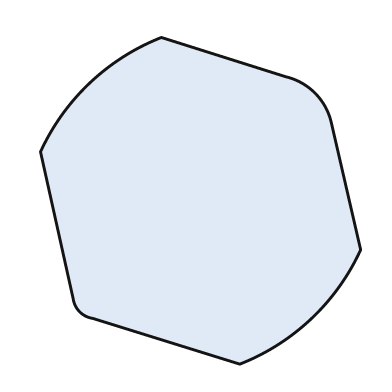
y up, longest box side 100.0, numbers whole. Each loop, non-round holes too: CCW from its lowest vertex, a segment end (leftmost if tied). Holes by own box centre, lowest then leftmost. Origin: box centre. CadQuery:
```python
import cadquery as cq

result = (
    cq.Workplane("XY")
    .moveTo(12.0, -50.0)
    .threePointArc((34.0, -36.0), (49.0, -15.0))
    .lineTo(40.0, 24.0)
    .threePointArc((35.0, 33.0), (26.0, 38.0))
    .lineTo(-12.0, 50.0)
    .threePointArc((-34.0, 36.0), (-49.0, 15.0))
    .lineTo(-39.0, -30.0)
    .threePointArc((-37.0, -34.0), (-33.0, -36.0))
    .close()
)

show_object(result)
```